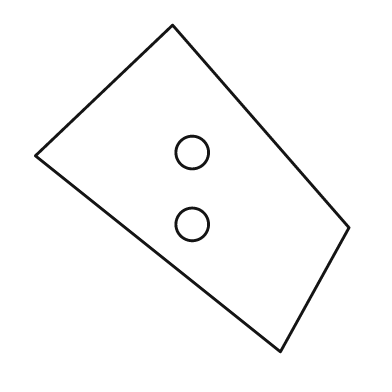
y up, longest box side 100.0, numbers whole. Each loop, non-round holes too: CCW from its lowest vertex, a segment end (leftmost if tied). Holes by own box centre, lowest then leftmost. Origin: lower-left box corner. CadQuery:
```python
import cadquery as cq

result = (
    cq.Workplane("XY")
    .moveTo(75.0, 0.0)
    .lineTo(96.0, 38.0)
    .lineTo(42.0, 100.0)
    .lineTo(0.0, 60.0)
    .close()
    .moveTo(48.0, 39.0)
    .circle(5.0)
    .moveTo(48.0, 61.0)
    .circle(5.0)
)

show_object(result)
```